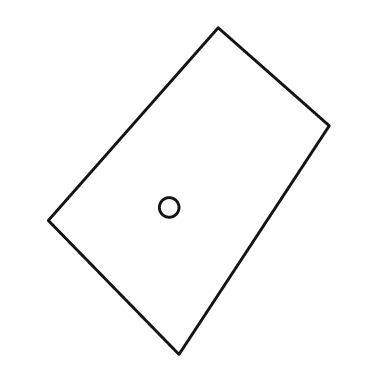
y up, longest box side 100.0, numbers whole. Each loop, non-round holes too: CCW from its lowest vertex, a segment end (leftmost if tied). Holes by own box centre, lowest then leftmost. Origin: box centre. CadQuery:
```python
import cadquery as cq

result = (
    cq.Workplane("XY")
    .moveTo(-3.0, -50.0)
    .lineTo(43.0, 20.0)
    .lineTo(9.0, 50.0)
    .lineTo(-43.0, -9.0)
    .close()
    .moveTo(-6.0, -5.0)
    .circle(3.0)
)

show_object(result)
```